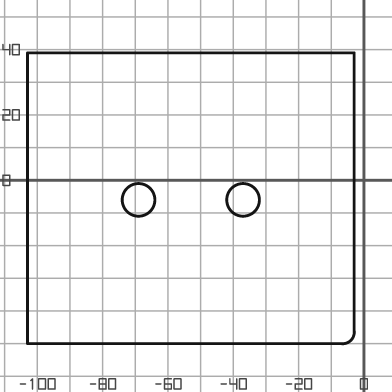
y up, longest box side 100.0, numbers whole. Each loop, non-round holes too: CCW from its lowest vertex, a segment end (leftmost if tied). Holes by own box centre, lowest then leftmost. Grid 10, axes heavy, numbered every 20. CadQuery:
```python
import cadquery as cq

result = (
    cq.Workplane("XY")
    .moveTo(-103.0, -50.0)
    .lineTo(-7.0, -50.0)
    .threePointArc((-4.0, -49.0), (-3.0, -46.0))
    .lineTo(-3.0, 39.0)
    .lineTo(-103.0, 39.0)
    .close()
    .moveTo(-69.0, -6.0)
    .circle(5.0)
    .moveTo(-37.0, -6.0)
    .circle(5.0)
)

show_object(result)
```